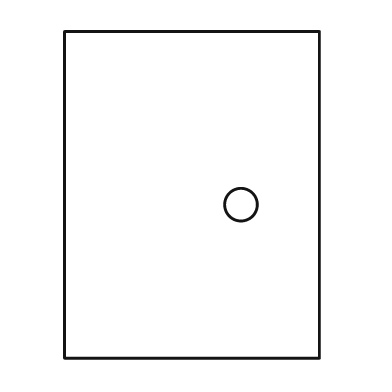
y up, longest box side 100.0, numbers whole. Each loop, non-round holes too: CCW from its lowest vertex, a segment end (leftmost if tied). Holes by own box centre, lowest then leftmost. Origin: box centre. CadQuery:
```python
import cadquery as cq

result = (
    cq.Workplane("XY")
    .moveTo(-39.0, -50.0)
    .lineTo(39.0, -50.0)
    .lineTo(39.0, 50.0)
    .lineTo(-39.0, 50.0)
    .close()
    .moveTo(15.0, -3.0)
    .circle(5.0)
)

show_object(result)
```